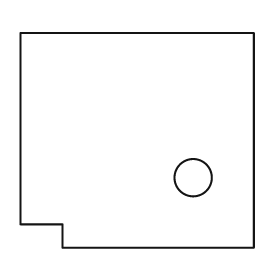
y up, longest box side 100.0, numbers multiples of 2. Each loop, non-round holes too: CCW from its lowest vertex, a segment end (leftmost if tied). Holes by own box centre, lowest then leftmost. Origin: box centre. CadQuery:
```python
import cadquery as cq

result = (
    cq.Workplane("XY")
    .moveTo(-32.0, -46.0)
    .lineTo(50.0, -46.0)
    .lineTo(50.0, 46.0)
    .lineTo(-50.0, 46.0)
    .lineTo(-50.0, -36.0)
    .lineTo(-32.0, -36.0)
    .close()
    .moveTo(24.0, -16.0)
    .circle(8.0)
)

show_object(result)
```